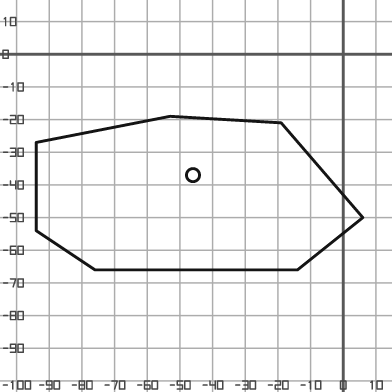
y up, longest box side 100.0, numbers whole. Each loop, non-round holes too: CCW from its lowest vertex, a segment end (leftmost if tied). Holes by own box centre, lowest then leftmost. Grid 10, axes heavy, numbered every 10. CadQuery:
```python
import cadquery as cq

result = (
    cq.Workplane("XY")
    .moveTo(-76.0, -66.0)
    .lineTo(-14.0, -66.0)
    .lineTo(6.0, -50.0)
    .lineTo(-19.0, -21.0)
    .lineTo(-53.0, -19.0)
    .lineTo(-94.0, -27.0)
    .lineTo(-94.0, -54.0)
    .close()
    .moveTo(-46.0, -37.0)
    .circle(2.0)
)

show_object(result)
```